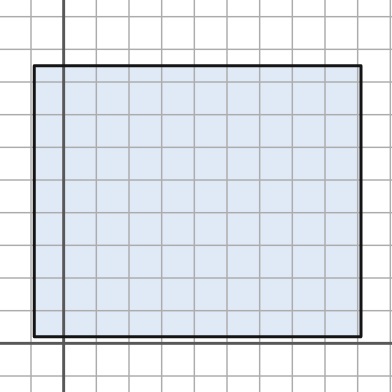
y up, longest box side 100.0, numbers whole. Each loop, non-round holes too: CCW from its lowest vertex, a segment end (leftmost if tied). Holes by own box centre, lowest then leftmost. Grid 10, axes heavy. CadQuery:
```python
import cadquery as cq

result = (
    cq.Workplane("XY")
    .moveTo(-9.0, 2.0)
    .lineTo(91.0, 2.0)
    .lineTo(91.0, 85.0)
    .lineTo(-9.0, 85.0)
    .close()
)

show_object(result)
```